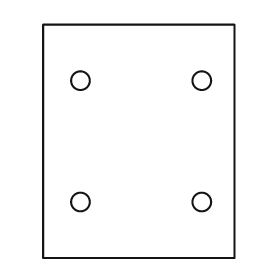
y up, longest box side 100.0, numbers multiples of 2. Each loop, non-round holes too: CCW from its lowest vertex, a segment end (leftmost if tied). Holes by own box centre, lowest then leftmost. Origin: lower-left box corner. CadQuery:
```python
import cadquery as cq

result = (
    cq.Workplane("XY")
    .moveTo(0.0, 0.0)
    .lineTo(82.0, 0.0)
    .lineTo(82.0, 100.0)
    .lineTo(0.0, 100.0)
    .close()
    .moveTo(16.0, 24.0)
    .circle(4.0)
    .moveTo(68.0, 24.0)
    .circle(4.0)
    .moveTo(16.0, 76.0)
    .circle(4.0)
    .moveTo(68.0, 76.0)
    .circle(4.0)
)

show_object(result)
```